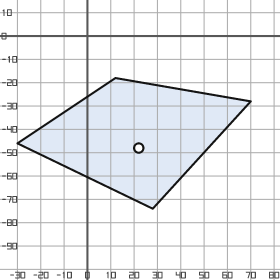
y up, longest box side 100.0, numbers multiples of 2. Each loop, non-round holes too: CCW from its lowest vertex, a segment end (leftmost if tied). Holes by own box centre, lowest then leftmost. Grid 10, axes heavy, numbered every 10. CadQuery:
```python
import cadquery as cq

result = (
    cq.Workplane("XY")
    .moveTo(28.0, -74.0)
    .lineTo(70.0, -28.0)
    .lineTo(12.0, -18.0)
    .lineTo(-30.0, -46.0)
    .close()
    .moveTo(22.0, -48.0)
    .circle(2.0)
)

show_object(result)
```